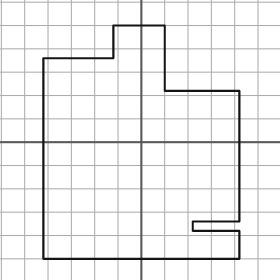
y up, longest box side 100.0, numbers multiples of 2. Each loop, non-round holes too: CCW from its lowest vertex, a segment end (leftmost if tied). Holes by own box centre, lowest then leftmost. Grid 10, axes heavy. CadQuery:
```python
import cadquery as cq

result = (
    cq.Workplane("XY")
    .moveTo(-42.0, -50.0)
    .lineTo(42.0, -50.0)
    .lineTo(42.0, -38.0)
    .lineTo(22.0, -38.0)
    .lineTo(22.0, -34.0)
    .lineTo(42.0, -34.0)
    .lineTo(42.0, 22.0)
    .lineTo(10.0, 22.0)
    .lineTo(10.0, 50.0)
    .lineTo(-12.0, 50.0)
    .lineTo(-12.0, 36.0)
    .lineTo(-42.0, 36.0)
    .close()
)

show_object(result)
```